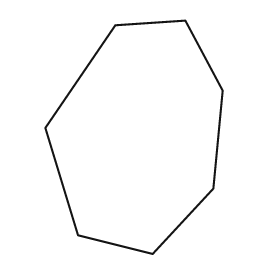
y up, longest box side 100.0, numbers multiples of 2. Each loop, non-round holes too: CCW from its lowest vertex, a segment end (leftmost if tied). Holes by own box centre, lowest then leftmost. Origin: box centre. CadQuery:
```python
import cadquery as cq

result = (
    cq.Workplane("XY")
    .moveTo(8.0, -50.0)
    .lineTo(34.0, -22.0)
    .lineTo(38.0, 20.0)
    .lineTo(22.0, 50.0)
    .lineTo(-8.0, 48.0)
    .lineTo(-38.0, 4.0)
    .lineTo(-24.0, -42.0)
    .close()
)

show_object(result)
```